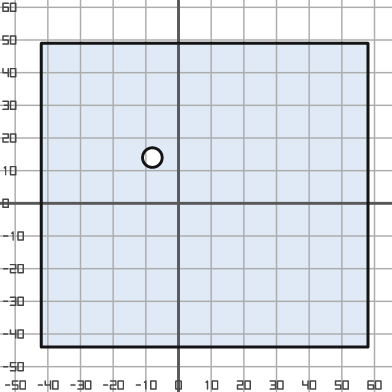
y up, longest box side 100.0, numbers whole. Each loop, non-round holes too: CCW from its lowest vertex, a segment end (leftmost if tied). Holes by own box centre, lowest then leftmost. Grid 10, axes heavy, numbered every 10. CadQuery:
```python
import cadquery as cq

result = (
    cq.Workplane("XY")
    .moveTo(-42.0, -44.0)
    .lineTo(58.0, -44.0)
    .lineTo(58.0, 49.0)
    .lineTo(-42.0, 49.0)
    .close()
    .moveTo(-8.0, 14.0)
    .circle(3.0)
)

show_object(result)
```